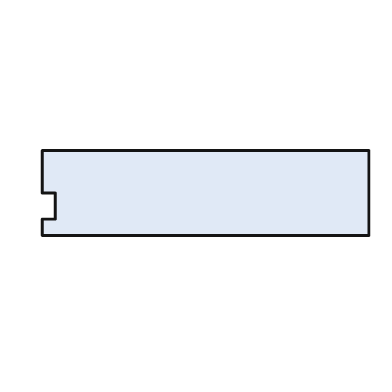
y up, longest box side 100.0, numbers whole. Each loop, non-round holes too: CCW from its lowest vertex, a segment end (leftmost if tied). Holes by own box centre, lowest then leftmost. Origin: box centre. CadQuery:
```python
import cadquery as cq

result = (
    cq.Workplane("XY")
    .moveTo(-50.0, -13.0)
    .lineTo(50.0, -13.0)
    .lineTo(50.0, 13.0)
    .lineTo(-50.0, 13.0)
    .lineTo(-50.0, 0.0)
    .lineTo(-46.0, 0.0)
    .lineTo(-46.0, -8.0)
    .lineTo(-50.0, -8.0)
    .close()
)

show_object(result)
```